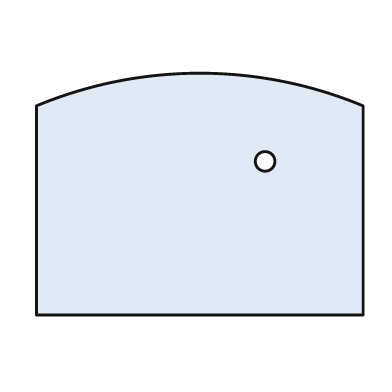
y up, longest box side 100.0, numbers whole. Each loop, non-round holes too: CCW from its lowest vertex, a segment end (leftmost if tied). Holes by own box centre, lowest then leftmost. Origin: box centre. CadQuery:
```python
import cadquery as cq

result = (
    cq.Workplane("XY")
    .moveTo(-50.0, -37.0)
    .lineTo(50.0, -37.0)
    .lineTo(50.0, 27.0)
    .threePointArc((0.0, 37.0), (-50.0, 27.0))
    .close()
    .moveTo(20.0, 10.0)
    .circle(3.0)
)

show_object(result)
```